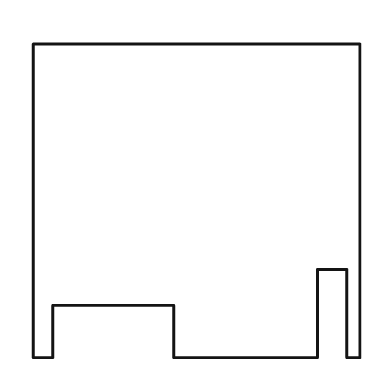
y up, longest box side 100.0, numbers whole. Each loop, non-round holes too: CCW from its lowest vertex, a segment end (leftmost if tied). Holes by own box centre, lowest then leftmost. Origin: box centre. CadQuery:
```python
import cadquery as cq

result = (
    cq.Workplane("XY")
    .moveTo(-50.0, -48.0)
    .lineTo(-44.0, -48.0)
    .lineTo(-44.0, -32.0)
    .lineTo(-7.0, -32.0)
    .lineTo(-7.0, -48.0)
    .lineTo(37.0, -48.0)
    .lineTo(37.0, -21.0)
    .lineTo(46.0, -21.0)
    .lineTo(46.0, -48.0)
    .lineTo(50.0, -48.0)
    .lineTo(50.0, 48.0)
    .lineTo(-50.0, 48.0)
    .close()
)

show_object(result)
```